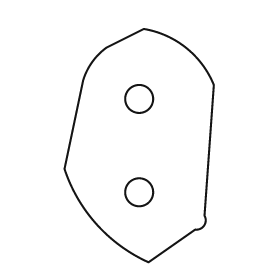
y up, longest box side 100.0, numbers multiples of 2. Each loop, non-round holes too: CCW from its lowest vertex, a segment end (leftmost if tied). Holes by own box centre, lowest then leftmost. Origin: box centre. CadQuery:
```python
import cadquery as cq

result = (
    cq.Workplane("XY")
    .moveTo(4.0, -50.0)
    .lineTo(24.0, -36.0)
    .threePointArc((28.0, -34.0), (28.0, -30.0))
    .lineTo(32.0, 26.0)
    .threePointArc((20.0, 42.0), (2.0, 50.0))
    .lineTo(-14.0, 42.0)
    .threePointArc((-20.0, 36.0), (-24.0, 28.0))
    .lineTo(-32.0, -10.0)
    .threePointArc((-18.0, -34.0), (4.0, -50.0))
    .close()
    .moveTo(0.0, -20.0)
    .circle(6.0)
    .moveTo(0.0, 20.0)
    .circle(6.0)
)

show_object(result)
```